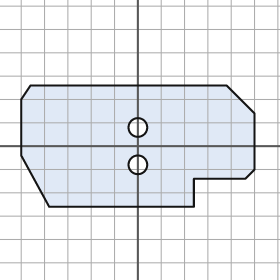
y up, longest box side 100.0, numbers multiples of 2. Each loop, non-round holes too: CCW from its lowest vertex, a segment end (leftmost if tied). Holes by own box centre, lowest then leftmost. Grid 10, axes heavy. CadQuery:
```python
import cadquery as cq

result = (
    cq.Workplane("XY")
    .moveTo(-38.0, -26.0)
    .lineTo(24.0, -26.0)
    .lineTo(24.0, -14.0)
    .lineTo(46.0, -14.0)
    .lineTo(50.0, -10.0)
    .lineTo(50.0, 14.0)
    .lineTo(38.0, 26.0)
    .lineTo(-46.0, 26.0)
    .lineTo(-50.0, 20.0)
    .lineTo(-50.0, -4.0)
    .close()
    .moveTo(0.0, -8.0)
    .circle(4.0)
    .moveTo(0.0, 8.0)
    .circle(4.0)
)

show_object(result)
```